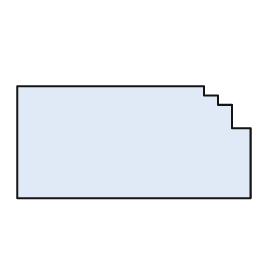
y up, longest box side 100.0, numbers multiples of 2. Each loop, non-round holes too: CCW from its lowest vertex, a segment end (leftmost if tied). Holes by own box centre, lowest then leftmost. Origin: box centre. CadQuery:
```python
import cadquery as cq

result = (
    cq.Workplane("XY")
    .moveTo(-50.0, -24.0)
    .lineTo(50.0, -24.0)
    .lineTo(50.0, 6.0)
    .lineTo(42.0, 6.0)
    .lineTo(42.0, 16.0)
    .lineTo(36.0, 16.0)
    .lineTo(36.0, 20.0)
    .lineTo(30.0, 20.0)
    .lineTo(30.0, 24.0)
    .lineTo(-50.0, 24.0)
    .close()
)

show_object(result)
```